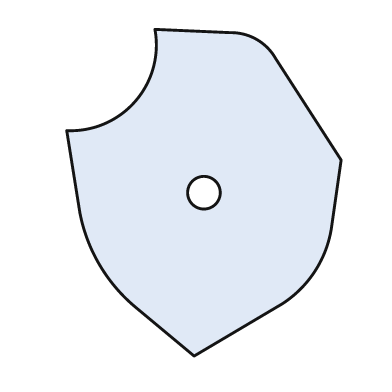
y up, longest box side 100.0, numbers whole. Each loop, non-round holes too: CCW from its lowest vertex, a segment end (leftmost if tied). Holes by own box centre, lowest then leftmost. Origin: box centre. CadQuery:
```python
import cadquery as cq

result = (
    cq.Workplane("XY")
    .moveTo(-3.0, -50.0)
    .lineTo(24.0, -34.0)
    .threePointArc((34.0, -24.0), (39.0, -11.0))
    .lineTo(42.0, 10.0)
    .lineTo(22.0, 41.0)
    .threePointArc((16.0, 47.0), (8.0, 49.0))
    .lineTo(-15.0, 50.0)
    .threePointArc((-21.0, 28.0), (-42.0, 19.0))
    .lineTo(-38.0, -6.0)
    .threePointArc((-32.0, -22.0), (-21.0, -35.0))
    .close()
    .moveTo(0.0, 0.0)
    .circle(5.0)
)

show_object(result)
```